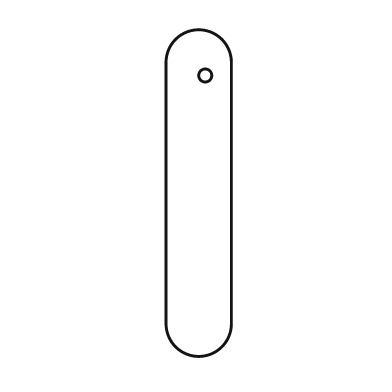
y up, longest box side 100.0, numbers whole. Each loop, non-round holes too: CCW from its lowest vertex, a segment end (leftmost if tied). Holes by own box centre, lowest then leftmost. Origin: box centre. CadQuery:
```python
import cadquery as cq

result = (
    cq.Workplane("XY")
    .moveTo(-10.0, -40.0)
    .threePointArc((0.0, -50.0), (10.0, -40.0))
    .lineTo(10.0, 40.0)
    .threePointArc((0.0, 50.0), (-10.0, 40.0))
    .close()
    .moveTo(2.0, 36.0)
    .circle(2.0)
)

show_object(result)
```